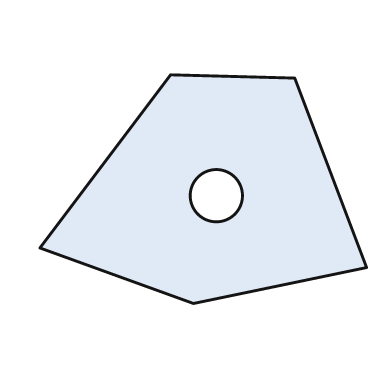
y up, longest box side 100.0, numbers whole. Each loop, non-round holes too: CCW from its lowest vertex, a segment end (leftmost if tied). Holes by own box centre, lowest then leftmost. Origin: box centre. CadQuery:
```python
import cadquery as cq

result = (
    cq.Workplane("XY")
    .moveTo(-3.0, -35.0)
    .lineTo(50.0, -24.0)
    .lineTo(28.0, 34.0)
    .lineTo(-10.0, 35.0)
    .lineTo(-50.0, -18.0)
    .close()
    .moveTo(4.0, -2.0)
    .circle(8.0)
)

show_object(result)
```